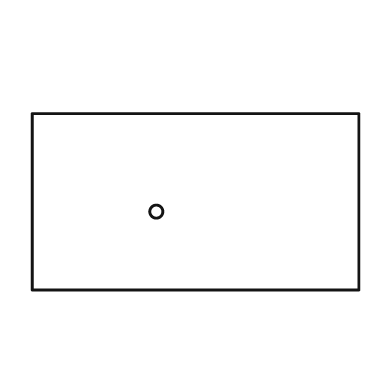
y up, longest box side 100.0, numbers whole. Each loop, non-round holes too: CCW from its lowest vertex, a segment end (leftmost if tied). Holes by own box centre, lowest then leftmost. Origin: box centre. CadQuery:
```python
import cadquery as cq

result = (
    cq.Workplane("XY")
    .moveTo(-50.0, -27.0)
    .lineTo(50.0, -27.0)
    .lineTo(50.0, 27.0)
    .lineTo(-50.0, 27.0)
    .close()
    .moveTo(-12.0, -3.0)
    .circle(2.0)
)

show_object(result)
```